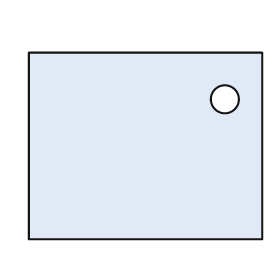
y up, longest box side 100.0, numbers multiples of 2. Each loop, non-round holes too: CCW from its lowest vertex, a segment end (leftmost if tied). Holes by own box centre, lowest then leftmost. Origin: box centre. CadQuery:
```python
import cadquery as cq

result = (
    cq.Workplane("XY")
    .moveTo(-50.0, -40.0)
    .lineTo(50.0, -40.0)
    .lineTo(50.0, 40.0)
    .lineTo(-50.0, 40.0)
    .close()
    .moveTo(34.0, 20.0)
    .circle(6.0)
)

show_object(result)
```